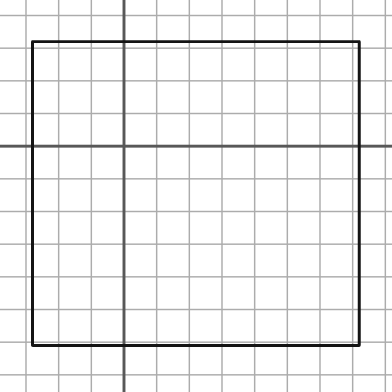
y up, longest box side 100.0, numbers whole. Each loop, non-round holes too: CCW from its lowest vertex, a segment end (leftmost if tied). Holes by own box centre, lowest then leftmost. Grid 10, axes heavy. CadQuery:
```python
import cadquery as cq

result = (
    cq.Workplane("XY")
    .moveTo(-28.0, -61.0)
    .lineTo(72.0, -61.0)
    .lineTo(72.0, 32.0)
    .lineTo(-28.0, 32.0)
    .close()
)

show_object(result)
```